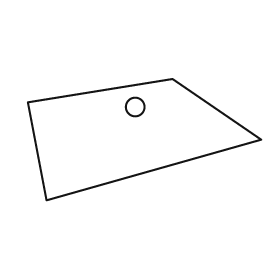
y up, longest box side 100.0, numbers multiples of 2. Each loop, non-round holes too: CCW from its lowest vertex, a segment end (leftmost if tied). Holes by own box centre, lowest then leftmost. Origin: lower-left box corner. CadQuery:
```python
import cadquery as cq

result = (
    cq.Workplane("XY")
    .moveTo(8.0, 0.0)
    .lineTo(100.0, 26.0)
    .lineTo(62.0, 52.0)
    .lineTo(0.0, 42.0)
    .close()
    .moveTo(46.0, 40.0)
    .circle(4.0)
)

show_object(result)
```